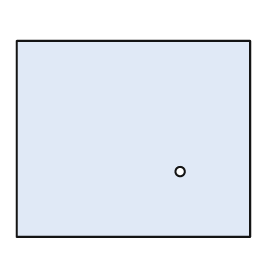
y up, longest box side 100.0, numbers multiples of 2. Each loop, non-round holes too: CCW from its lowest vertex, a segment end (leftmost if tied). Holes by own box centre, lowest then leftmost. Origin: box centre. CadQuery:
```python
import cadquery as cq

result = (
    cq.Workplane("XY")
    .moveTo(-50.0, -42.0)
    .lineTo(50.0, -42.0)
    .lineTo(50.0, 42.0)
    .lineTo(-50.0, 42.0)
    .close()
    .moveTo(20.0, -14.0)
    .circle(2.0)
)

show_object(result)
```